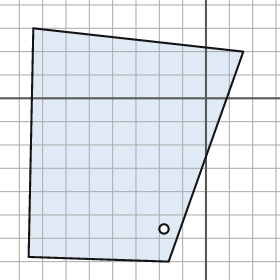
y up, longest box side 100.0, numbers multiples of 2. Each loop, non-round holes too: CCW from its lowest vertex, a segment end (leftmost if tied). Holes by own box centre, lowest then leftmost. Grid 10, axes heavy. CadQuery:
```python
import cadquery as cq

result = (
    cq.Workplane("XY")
    .moveTo(-16.0, -70.0)
    .lineTo(16.0, 20.0)
    .lineTo(-74.0, 30.0)
    .lineTo(-76.0, -68.0)
    .close()
    .moveTo(-18.0, -56.0)
    .circle(2.0)
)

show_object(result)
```